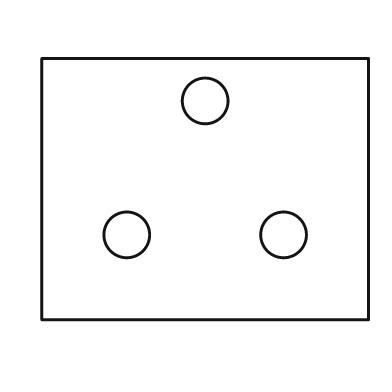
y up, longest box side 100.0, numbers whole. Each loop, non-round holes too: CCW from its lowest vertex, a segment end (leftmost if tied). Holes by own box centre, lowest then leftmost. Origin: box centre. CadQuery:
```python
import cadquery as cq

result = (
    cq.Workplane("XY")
    .moveTo(-50.0, -40.0)
    .lineTo(50.0, -40.0)
    .lineTo(50.0, 40.0)
    .lineTo(-50.0, 40.0)
    .close()
    .moveTo(-24.0, -14.0)
    .circle(7.0)
    .moveTo(24.0, -14.0)
    .circle(7.0)
    .moveTo(0.0, 27.0)
    .circle(7.0)
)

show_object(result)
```